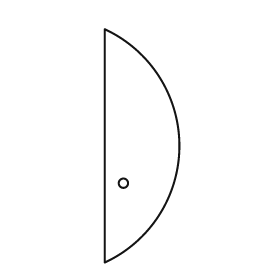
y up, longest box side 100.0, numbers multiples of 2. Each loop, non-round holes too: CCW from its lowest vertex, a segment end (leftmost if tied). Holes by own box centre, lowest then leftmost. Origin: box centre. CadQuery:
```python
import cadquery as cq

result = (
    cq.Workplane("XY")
    .moveTo(-16.0, -50.0)
    .threePointArc((16.0, 0.0), (-16.0, 50.0))
    .close()
    .moveTo(-8.0, -16.0)
    .circle(2.0)
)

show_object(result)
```